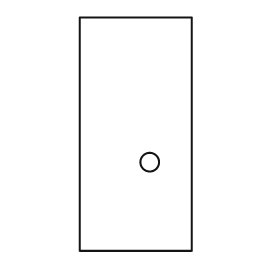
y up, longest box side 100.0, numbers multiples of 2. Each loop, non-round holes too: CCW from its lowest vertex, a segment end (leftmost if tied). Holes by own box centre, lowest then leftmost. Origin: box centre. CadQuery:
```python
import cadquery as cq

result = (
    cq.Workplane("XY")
    .moveTo(-24.0, -50.0)
    .lineTo(24.0, -50.0)
    .lineTo(24.0, 50.0)
    .lineTo(-24.0, 50.0)
    .close()
    .moveTo(6.0, -12.0)
    .circle(4.0)
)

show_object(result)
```